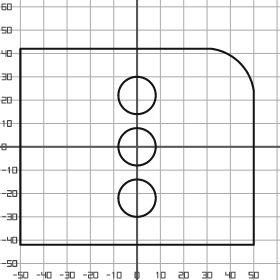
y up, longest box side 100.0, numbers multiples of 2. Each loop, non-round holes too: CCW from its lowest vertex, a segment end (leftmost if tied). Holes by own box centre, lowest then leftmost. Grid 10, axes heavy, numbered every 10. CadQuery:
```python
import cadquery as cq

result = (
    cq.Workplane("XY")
    .moveTo(-50.0, -42.0)
    .lineTo(50.0, -42.0)
    .lineTo(50.0, 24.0)
    .threePointArc((44.0, 36.0), (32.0, 42.0))
    .lineTo(-50.0, 42.0)
    .close()
    .moveTo(0.0, -22.0)
    .circle(8.0)
    .moveTo(0.0, 0.0)
    .circle(8.0)
    .moveTo(0.0, 22.0)
    .circle(8.0)
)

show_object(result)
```